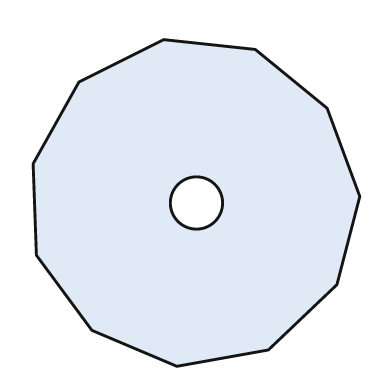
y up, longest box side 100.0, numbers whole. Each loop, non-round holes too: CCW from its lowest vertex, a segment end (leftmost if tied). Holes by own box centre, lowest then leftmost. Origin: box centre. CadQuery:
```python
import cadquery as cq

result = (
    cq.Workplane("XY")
    .moveTo(-6.0, -50.0)
    .lineTo(22.0, -45.0)
    .lineTo(43.0, -25.0)
    .lineTo(50.0, 2.0)
    .lineTo(40.0, 29.0)
    .lineTo(18.0, 47.0)
    .lineTo(-10.0, 50.0)
    .lineTo(-36.0, 37.0)
    .lineTo(-50.0, 12.0)
    .lineTo(-49.0, -16.0)
    .lineTo(-32.0, -39.0)
    .close()
    .moveTo(0.0, 0.0)
    .circle(8.0)
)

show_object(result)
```